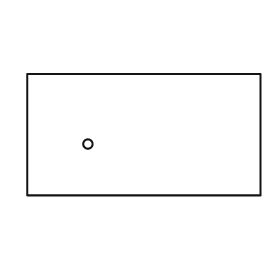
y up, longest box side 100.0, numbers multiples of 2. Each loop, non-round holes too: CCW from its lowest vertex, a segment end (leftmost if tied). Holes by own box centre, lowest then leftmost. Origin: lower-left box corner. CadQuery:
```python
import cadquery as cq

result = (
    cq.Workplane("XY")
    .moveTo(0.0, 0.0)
    .lineTo(100.0, 0.0)
    .lineTo(100.0, 52.0)
    .lineTo(0.0, 52.0)
    .close()
    .moveTo(26.0, 22.0)
    .circle(2.0)
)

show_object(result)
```